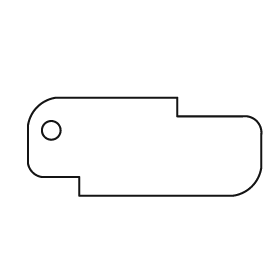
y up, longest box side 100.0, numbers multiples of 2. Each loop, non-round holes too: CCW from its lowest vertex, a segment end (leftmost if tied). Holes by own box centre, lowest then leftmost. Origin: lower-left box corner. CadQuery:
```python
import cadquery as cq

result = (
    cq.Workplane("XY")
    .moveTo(22.0, 0.0)
    .lineTo(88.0, 0.0)
    .threePointArc((96.0, 4.0), (100.0, 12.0))
    .lineTo(100.0, 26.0)
    .threePointArc((98.0, 32.0), (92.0, 34.0))
    .lineTo(64.0, 34.0)
    .lineTo(64.0, 42.0)
    .lineTo(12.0, 42.0)
    .threePointArc((4.0, 38.0), (0.0, 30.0))
    .lineTo(0.0, 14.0)
    .threePointArc((2.0, 10.0), (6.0, 8.0))
    .lineTo(22.0, 8.0)
    .close()
    .moveTo(10.0, 28.0)
    .circle(4.0)
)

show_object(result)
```